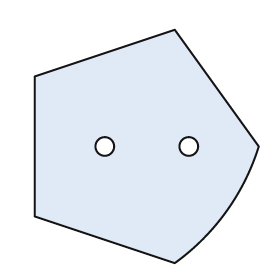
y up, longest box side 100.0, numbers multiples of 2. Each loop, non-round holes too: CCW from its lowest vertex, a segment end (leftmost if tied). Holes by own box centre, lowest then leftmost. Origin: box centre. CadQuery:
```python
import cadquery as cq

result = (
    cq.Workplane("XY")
    .moveTo(12.0, -50.0)
    .threePointArc((34.0, -28.0), (48.0, 0.0))
    .lineTo(12.0, 50.0)
    .lineTo(-48.0, 30.0)
    .lineTo(-48.0, -30.0)
    .close()
    .moveTo(-18.0, 0.0)
    .circle(4.0)
    .moveTo(18.0, 0.0)
    .circle(4.0)
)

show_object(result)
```